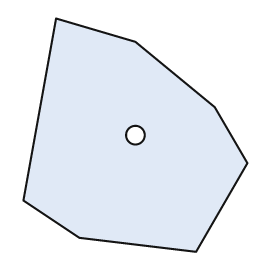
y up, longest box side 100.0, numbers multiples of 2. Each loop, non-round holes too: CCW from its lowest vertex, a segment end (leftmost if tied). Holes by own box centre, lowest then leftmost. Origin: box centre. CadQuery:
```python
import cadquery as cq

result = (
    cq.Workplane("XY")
    .moveTo(26.0, -50.0)
    .lineTo(48.0, -12.0)
    .lineTo(34.0, 12.0)
    .lineTo(0.0, 40.0)
    .lineTo(-34.0, 50.0)
    .lineTo(-48.0, -28.0)
    .lineTo(-24.0, -44.0)
    .close()
    .moveTo(0.0, 0.0)
    .circle(4.0)
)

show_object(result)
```